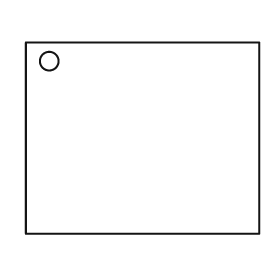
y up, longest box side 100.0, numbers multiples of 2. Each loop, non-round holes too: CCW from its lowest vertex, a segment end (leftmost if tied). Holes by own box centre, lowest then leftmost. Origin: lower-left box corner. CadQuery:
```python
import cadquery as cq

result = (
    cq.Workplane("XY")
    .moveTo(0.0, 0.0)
    .lineTo(100.0, 0.0)
    .lineTo(100.0, 82.0)
    .lineTo(0.0, 82.0)
    .close()
    .moveTo(10.0, 74.0)
    .circle(4.0)
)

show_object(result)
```